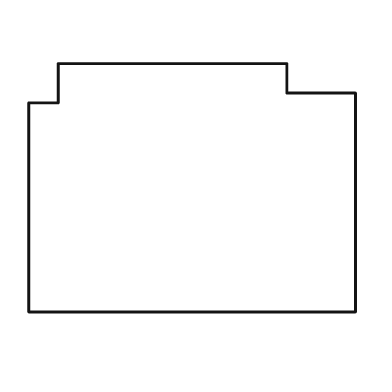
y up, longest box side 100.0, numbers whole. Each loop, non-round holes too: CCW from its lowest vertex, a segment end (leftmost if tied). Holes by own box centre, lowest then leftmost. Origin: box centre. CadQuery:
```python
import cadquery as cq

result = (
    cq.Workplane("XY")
    .moveTo(-50.0, -38.0)
    .lineTo(50.0, -38.0)
    .lineTo(50.0, 29.0)
    .lineTo(29.0, 29.0)
    .lineTo(29.0, 38.0)
    .lineTo(-41.0, 38.0)
    .lineTo(-41.0, 26.0)
    .lineTo(-50.0, 26.0)
    .close()
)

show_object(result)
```